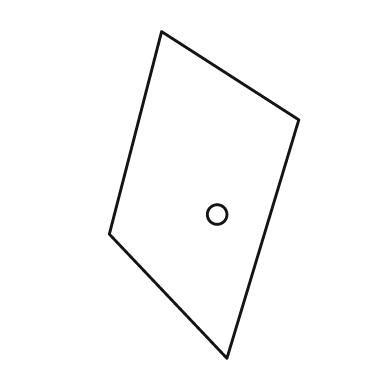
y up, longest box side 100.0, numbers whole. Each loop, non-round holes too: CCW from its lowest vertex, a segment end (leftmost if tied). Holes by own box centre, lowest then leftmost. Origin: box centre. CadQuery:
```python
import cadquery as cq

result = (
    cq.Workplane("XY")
    .moveTo(7.0, -50.0)
    .lineTo(29.0, 23.0)
    .lineTo(-13.0, 50.0)
    .lineTo(-29.0, -12.0)
    .close()
    .moveTo(4.0, -6.0)
    .circle(3.0)
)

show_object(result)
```